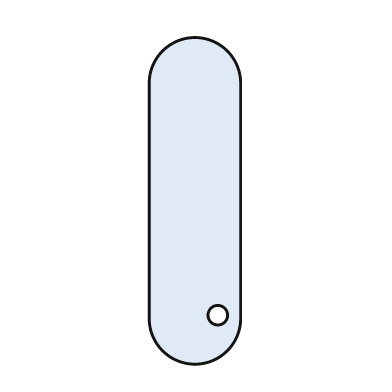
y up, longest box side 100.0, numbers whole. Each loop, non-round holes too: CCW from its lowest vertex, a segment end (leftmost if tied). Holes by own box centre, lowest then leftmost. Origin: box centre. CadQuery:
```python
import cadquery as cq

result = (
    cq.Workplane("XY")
    .moveTo(-14.0, -36.0)
    .threePointArc((0.0, -50.0), (14.0, -36.0))
    .lineTo(14.0, 36.0)
    .threePointArc((0.0, 50.0), (-14.0, 36.0))
    .close()
    .moveTo(7.0, -35.0)
    .circle(3.0)
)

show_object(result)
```